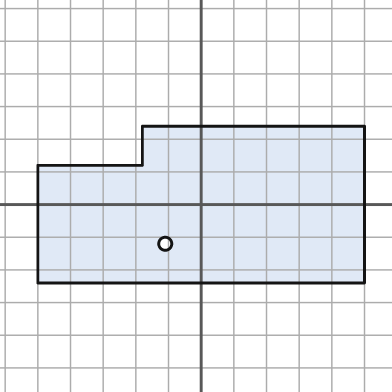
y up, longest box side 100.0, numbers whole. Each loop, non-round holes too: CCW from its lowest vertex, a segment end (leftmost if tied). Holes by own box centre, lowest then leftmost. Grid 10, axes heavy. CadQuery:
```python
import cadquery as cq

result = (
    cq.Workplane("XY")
    .moveTo(-50.0, -24.0)
    .lineTo(50.0, -24.0)
    .lineTo(50.0, 24.0)
    .lineTo(-18.0, 24.0)
    .lineTo(-18.0, 12.0)
    .lineTo(-50.0, 12.0)
    .close()
    .moveTo(-11.0, -12.0)
    .circle(2.0)
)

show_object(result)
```